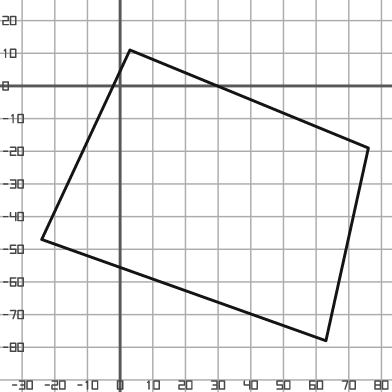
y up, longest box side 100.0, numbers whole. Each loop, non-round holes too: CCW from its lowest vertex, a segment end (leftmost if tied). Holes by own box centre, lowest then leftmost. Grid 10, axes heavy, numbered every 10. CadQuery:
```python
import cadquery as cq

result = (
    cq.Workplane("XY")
    .moveTo(63.0, -78.0)
    .lineTo(76.0, -19.0)
    .lineTo(3.0, 11.0)
    .lineTo(-24.0, -47.0)
    .close()
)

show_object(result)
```